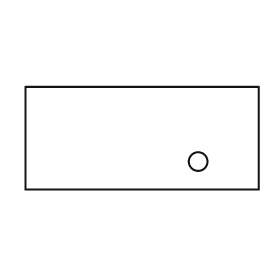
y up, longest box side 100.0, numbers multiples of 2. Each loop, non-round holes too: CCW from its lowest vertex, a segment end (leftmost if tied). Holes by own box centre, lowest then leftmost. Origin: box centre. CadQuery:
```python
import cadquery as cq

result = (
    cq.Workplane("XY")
    .moveTo(-50.0, -22.0)
    .lineTo(50.0, -22.0)
    .lineTo(50.0, 22.0)
    .lineTo(-50.0, 22.0)
    .close()
    .moveTo(24.0, -10.0)
    .circle(4.0)
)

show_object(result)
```